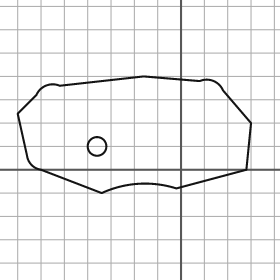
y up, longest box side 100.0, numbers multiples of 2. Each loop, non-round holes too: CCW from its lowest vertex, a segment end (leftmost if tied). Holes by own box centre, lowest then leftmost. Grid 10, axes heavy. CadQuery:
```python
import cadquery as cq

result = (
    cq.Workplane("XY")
    .moveTo(-34.0, -10.0)
    .threePointArc((-18.0, -6.0), (-2.0, -8.0))
    .lineTo(28.0, 0.0)
    .lineTo(30.0, 20.0)
    .lineTo(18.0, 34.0)
    .threePointArc((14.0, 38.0), (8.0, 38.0))
    .lineTo(-16.0, 40.0)
    .lineTo(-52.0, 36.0)
    .threePointArc((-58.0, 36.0), (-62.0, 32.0))
    .lineTo(-70.0, 24.0)
    .lineTo(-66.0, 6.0)
    .threePointArc((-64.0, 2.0), (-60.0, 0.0))
    .close()
    .moveTo(-36.0, 10.0)
    .circle(4.0)
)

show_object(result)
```